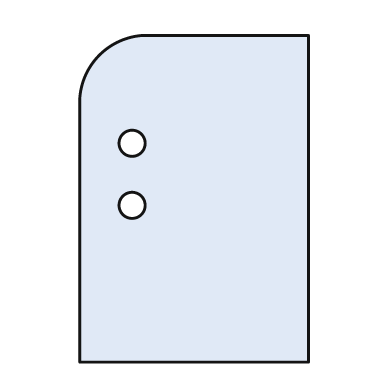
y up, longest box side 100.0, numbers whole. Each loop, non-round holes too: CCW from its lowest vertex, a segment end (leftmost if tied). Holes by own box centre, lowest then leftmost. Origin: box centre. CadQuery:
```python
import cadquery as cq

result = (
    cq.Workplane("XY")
    .moveTo(-35.0, -50.0)
    .lineTo(35.0, -50.0)
    .lineTo(35.0, 50.0)
    .lineTo(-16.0, 50.0)
    .threePointArc((-29.0, 44.0), (-35.0, 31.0))
    .close()
    .moveTo(-19.0, -2.0)
    .circle(4.0)
    .moveTo(-19.0, 17.0)
    .circle(4.0)
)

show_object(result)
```